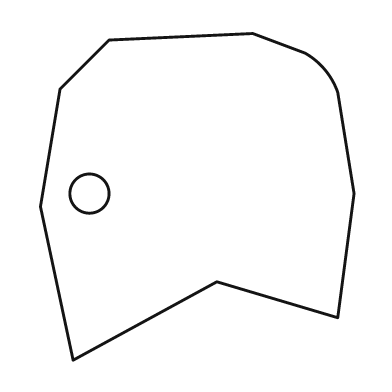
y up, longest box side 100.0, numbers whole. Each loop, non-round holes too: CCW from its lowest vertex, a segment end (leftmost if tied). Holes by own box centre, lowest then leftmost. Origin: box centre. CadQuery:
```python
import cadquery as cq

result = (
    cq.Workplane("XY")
    .moveTo(-38.0, -50.0)
    .lineTo(6.0, -26.0)
    .lineTo(43.0, -37.0)
    .lineTo(48.0, 1.0)
    .lineTo(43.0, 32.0)
    .threePointArc((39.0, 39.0), (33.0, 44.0))
    .lineTo(17.0, 50.0)
    .lineTo(-27.0, 48.0)
    .lineTo(-42.0, 33.0)
    .lineTo(-48.0, -3.0)
    .close()
    .moveTo(-33.0, 1.0)
    .circle(6.0)
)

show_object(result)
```